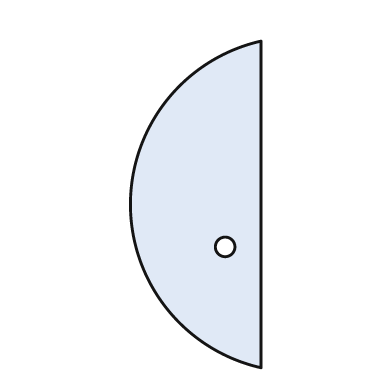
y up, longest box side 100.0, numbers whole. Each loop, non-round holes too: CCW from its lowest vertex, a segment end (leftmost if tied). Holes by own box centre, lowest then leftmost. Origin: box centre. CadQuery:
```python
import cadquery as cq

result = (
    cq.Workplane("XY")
    .moveTo(20.0, -50.0)
    .lineTo(20.0, 50.0)
    .threePointArc((-20.0, 0.0), (20.0, -50.0))
    .close()
    .moveTo(9.0, -13.0)
    .circle(3.0)
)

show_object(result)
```